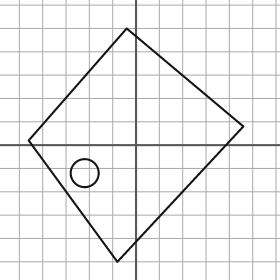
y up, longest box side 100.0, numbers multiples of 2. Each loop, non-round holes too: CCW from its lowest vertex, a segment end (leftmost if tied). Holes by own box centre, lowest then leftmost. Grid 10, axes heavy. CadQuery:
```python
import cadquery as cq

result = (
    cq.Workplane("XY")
    .moveTo(-8.0, -50.0)
    .lineTo(46.0, 8.0)
    .lineTo(-4.0, 50.0)
    .lineTo(-46.0, 2.0)
    .close()
    .moveTo(-22.0, -12.0)
    .circle(6.0)
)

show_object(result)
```